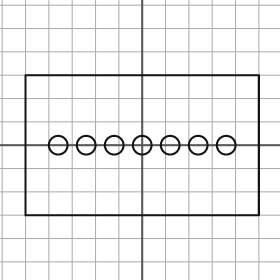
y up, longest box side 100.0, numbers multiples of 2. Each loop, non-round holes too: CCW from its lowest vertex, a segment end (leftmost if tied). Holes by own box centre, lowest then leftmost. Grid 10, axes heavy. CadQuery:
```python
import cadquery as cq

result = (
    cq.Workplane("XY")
    .moveTo(-50.0, -30.0)
    .lineTo(50.0, -30.0)
    .lineTo(50.0, 30.0)
    .lineTo(-50.0, 30.0)
    .close()
    .moveTo(-36.0, 0.0)
    .circle(4.0)
    .moveTo(-24.0, 0.0)
    .circle(4.0)
    .moveTo(-12.0, 0.0)
    .circle(4.0)
    .moveTo(0.0, 0.0)
    .circle(4.0)
    .moveTo(12.0, 0.0)
    .circle(4.0)
    .moveTo(24.0, 0.0)
    .circle(4.0)
    .moveTo(36.0, 0.0)
    .circle(4.0)
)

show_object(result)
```